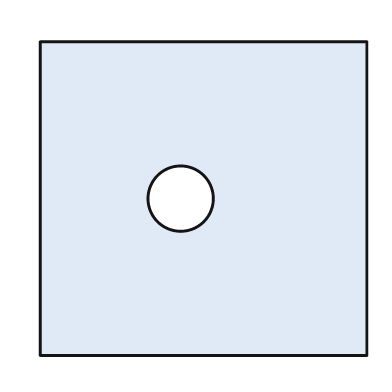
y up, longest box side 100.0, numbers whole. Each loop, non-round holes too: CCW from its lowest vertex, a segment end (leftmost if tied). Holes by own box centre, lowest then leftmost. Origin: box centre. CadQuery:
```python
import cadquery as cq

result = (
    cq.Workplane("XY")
    .moveTo(-50.0, -48.0)
    .lineTo(50.0, -48.0)
    .lineTo(50.0, 48.0)
    .lineTo(-50.0, 48.0)
    .close()
    .moveTo(-7.0, 0.0)
    .circle(10.0)
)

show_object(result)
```